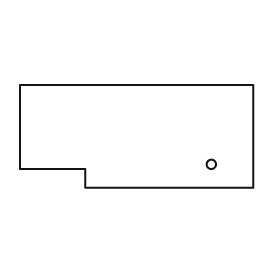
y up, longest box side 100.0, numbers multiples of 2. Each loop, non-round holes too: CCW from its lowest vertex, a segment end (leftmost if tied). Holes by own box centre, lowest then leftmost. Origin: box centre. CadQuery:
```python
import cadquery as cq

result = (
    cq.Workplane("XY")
    .moveTo(-22.0, -22.0)
    .lineTo(50.0, -22.0)
    .lineTo(50.0, 22.0)
    .lineTo(-50.0, 22.0)
    .lineTo(-50.0, -14.0)
    .lineTo(-22.0, -14.0)
    .close()
    .moveTo(32.0, -12.0)
    .circle(2.0)
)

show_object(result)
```